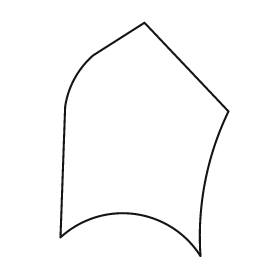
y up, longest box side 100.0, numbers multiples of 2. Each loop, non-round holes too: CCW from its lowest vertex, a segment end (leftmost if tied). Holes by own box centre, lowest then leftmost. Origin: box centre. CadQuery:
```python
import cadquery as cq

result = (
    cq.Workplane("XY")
    .moveTo(24.0, -50.0)
    .threePointArc((26.0, -18.0), (36.0, 12.0))
    .lineTo(0.0, 50.0)
    .lineTo(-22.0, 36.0)
    .threePointArc((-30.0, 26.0), (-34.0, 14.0))
    .lineTo(-36.0, -42.0)
    .threePointArc((-4.0, -32.0), (24.0, -50.0))
    .close()
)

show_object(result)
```